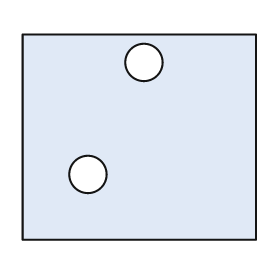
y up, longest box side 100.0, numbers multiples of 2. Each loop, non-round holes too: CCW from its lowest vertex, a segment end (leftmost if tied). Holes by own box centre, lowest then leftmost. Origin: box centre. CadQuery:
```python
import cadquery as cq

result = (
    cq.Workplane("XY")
    .moveTo(-50.0, -44.0)
    .lineTo(50.0, -44.0)
    .lineTo(50.0, 44.0)
    .lineTo(-50.0, 44.0)
    .close()
    .moveTo(-22.0, -16.0)
    .circle(8.0)
    .moveTo(2.0, 32.0)
    .circle(8.0)
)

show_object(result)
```